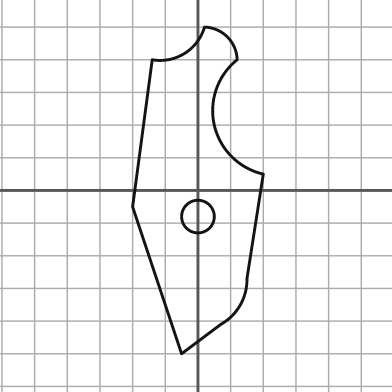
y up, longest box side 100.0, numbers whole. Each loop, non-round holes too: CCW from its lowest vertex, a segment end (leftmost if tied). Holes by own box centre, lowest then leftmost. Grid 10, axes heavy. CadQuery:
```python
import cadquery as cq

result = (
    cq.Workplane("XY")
    .moveTo(-5.0, -50.0)
    .lineTo(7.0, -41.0)
    .threePointArc((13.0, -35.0), (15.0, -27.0))
    .lineTo(20.0, 5.0)
    .threePointArc((5.0, 20.0), (12.0, 40.0))
    .threePointArc((9.0, 47.0), (2.0, 50.0))
    .threePointArc((-4.0, 42.0), (-14.0, 40.0))
    .lineTo(-20.0, -5.0)
    .close()
    .moveTo(0.0, -8.0)
    .circle(5.0)
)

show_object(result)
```